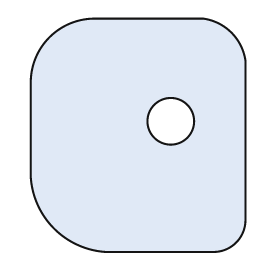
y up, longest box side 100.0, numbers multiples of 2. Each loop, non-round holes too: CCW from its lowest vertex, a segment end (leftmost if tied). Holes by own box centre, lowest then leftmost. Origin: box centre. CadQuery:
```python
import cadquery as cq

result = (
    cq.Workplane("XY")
    .moveTo(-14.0, -50.0)
    .lineTo(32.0, -50.0)
    .threePointArc((42.0, -46.0), (46.0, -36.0))
    .lineTo(46.0, 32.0)
    .threePointArc((40.0, 44.0), (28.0, 50.0))
    .lineTo(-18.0, 50.0)
    .threePointArc((-38.0, 42.0), (-46.0, 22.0))
    .lineTo(-46.0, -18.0)
    .threePointArc((-36.0, -40.0), (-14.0, -50.0))
    .close()
    .moveTo(14.0, 6.0)
    .circle(10.0)
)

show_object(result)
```